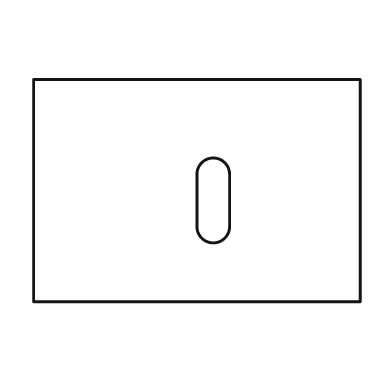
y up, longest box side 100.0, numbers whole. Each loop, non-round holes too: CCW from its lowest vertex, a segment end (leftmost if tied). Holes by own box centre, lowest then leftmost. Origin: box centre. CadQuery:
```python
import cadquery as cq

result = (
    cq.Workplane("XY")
    .moveTo(-50.0, -34.0)
    .lineTo(50.0, -34.0)
    .lineTo(50.0, 34.0)
    .lineTo(-50.0, 34.0)
    .close()
    .moveTo(0.0, -11.0)
    .threePointArc((5.0, -16.0), (10.0, -11.0))
    .lineTo(10.0, 5.0)
    .threePointArc((5.0, 10.0), (0.0, 5.0))
    .close()
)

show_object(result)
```